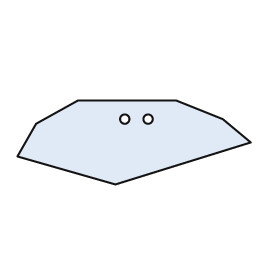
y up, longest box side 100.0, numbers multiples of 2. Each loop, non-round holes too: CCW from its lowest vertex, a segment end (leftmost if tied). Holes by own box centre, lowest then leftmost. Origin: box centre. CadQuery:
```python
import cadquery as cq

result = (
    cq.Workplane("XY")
    .moveTo(-8.0, -18.0)
    .lineTo(50.0, 0.0)
    .lineTo(38.0, 10.0)
    .lineTo(18.0, 18.0)
    .lineTo(-24.0, 18.0)
    .lineTo(-42.0, 8.0)
    .lineTo(-50.0, -6.0)
    .close()
    .moveTo(-4.0, 10.0)
    .circle(2.0)
    .moveTo(6.0, 10.0)
    .circle(2.0)
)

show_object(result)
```